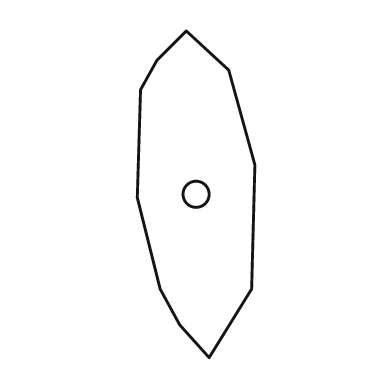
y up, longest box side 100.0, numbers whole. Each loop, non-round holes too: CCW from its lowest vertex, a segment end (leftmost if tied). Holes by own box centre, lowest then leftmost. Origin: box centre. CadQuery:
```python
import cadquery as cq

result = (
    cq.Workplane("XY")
    .moveTo(4.0, -50.0)
    .lineTo(17.0, -29.0)
    .lineTo(18.0, 9.0)
    .lineTo(10.0, 38.0)
    .lineTo(-3.0, 50.0)
    .lineTo(-12.0, 41.0)
    .lineTo(-17.0, 32.0)
    .lineTo(-18.0, -1.0)
    .lineTo(-11.0, -29.0)
    .lineTo(-5.0, -40.0)
    .close()
    .moveTo(0.0, 0.0)
    .circle(4.0)
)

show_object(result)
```